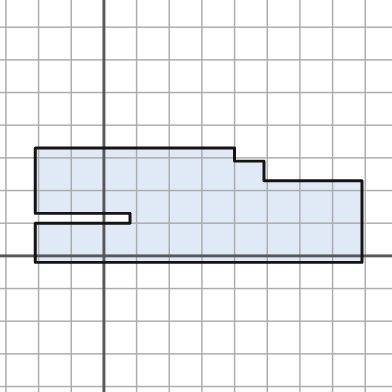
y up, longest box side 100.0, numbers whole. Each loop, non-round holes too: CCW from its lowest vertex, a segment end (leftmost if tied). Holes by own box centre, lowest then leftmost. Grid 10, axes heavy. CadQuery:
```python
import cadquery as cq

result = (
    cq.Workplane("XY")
    .moveTo(-21.0, -2.0)
    .lineTo(79.0, -2.0)
    .lineTo(79.0, 23.0)
    .lineTo(49.0, 23.0)
    .lineTo(49.0, 29.0)
    .lineTo(40.0, 29.0)
    .lineTo(40.0, 33.0)
    .lineTo(-21.0, 33.0)
    .lineTo(-21.0, 13.0)
    .lineTo(8.0, 13.0)
    .lineTo(8.0, 10.0)
    .lineTo(-21.0, 10.0)
    .close()
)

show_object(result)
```